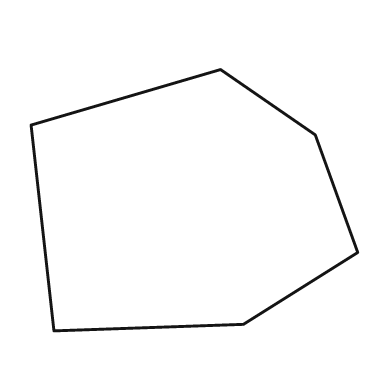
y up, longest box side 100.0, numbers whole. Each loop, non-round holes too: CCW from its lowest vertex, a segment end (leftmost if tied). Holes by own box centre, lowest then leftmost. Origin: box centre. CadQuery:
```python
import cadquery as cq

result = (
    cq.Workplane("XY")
    .moveTo(-43.0, -40.0)
    .lineTo(15.0, -38.0)
    .lineTo(50.0, -16.0)
    .lineTo(37.0, 20.0)
    .lineTo(8.0, 40.0)
    .lineTo(-50.0, 23.0)
    .close()
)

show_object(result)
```